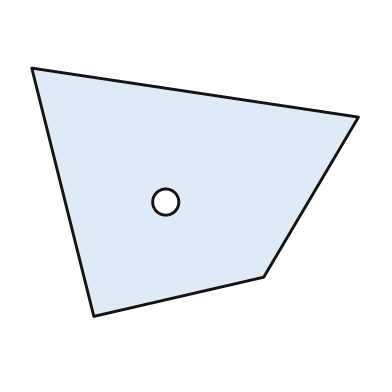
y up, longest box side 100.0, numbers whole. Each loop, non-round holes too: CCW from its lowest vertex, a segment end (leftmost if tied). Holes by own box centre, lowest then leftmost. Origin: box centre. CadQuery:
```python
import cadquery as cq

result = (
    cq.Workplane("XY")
    .moveTo(-31.0, -38.0)
    .lineTo(21.0, -26.0)
    .lineTo(50.0, 23.0)
    .lineTo(-50.0, 38.0)
    .close()
    .moveTo(-9.0, -3.0)
    .circle(4.0)
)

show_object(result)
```